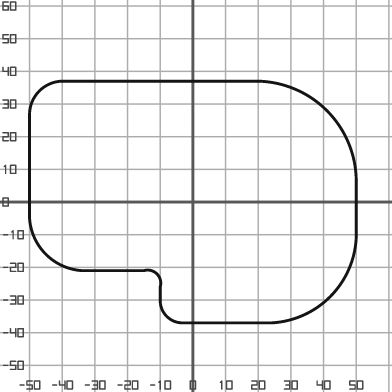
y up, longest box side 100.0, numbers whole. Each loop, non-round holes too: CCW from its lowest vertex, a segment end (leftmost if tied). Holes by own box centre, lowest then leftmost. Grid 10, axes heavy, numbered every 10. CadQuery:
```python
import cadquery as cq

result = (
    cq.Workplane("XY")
    .moveTo(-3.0, -37.0)
    .lineTo(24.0, -37.0)
    .threePointArc((42.0, -29.0), (50.0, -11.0))
    .lineTo(50.0, 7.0)
    .threePointArc((41.0, 28.0), (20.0, 37.0))
    .lineTo(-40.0, 37.0)
    .threePointArc((-47.0, 34.0), (-50.0, 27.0))
    .lineTo(-50.0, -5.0)
    .threePointArc((-45.0, -16.0), (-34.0, -21.0))
    .lineTo(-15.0, -21.0)
    .threePointArc((-11.0, -22.0), (-10.0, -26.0))
    .lineTo(-10.0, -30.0)
    .threePointArc((-8.0, -35.0), (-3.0, -37.0))
    .close()
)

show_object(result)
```